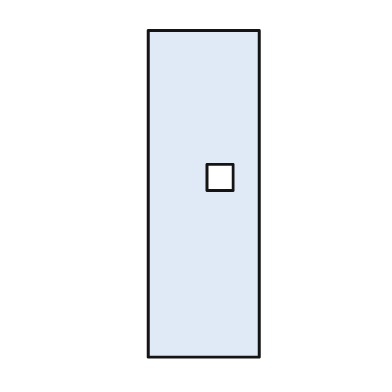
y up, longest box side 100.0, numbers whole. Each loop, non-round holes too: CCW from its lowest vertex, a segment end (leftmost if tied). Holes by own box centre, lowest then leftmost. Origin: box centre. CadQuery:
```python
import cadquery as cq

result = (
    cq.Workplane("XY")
    .moveTo(-17.0, -50.0)
    .lineTo(17.0, -50.0)
    .lineTo(17.0, 50.0)
    .lineTo(-17.0, 50.0)
    .close()
    .moveTo(1.0, 1.0)
    .lineTo(9.0, 1.0)
    .lineTo(9.0, 9.0)
    .lineTo(1.0, 9.0)
    .close()
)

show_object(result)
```